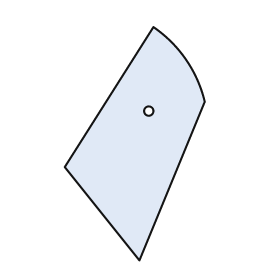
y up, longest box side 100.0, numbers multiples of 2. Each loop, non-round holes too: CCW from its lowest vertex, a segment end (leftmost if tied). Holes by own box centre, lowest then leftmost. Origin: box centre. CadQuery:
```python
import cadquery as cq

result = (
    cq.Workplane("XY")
    .moveTo(2.0, -50.0)
    .lineTo(30.0, 18.0)
    .threePointArc((22.0, 36.0), (8.0, 50.0))
    .lineTo(-30.0, -10.0)
    .close()
    .moveTo(6.0, 14.0)
    .circle(2.0)
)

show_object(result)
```